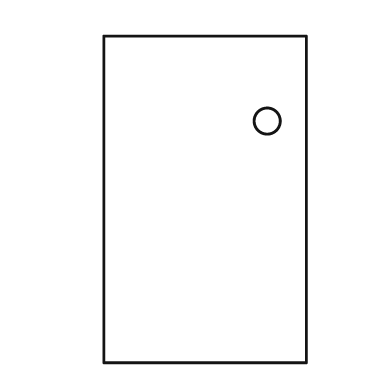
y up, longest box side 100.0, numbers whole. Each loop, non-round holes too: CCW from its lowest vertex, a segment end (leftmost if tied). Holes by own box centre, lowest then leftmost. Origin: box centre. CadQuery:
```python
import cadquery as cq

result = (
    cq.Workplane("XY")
    .moveTo(-31.0, -50.0)
    .lineTo(31.0, -50.0)
    .lineTo(31.0, 50.0)
    .lineTo(-31.0, 50.0)
    .close()
    .moveTo(19.0, 24.0)
    .circle(4.0)
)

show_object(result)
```